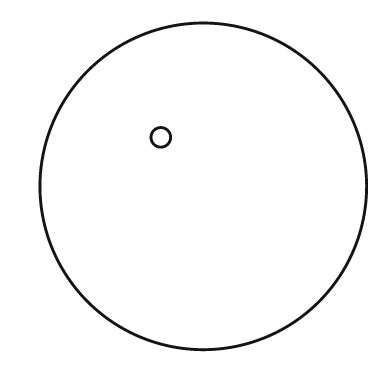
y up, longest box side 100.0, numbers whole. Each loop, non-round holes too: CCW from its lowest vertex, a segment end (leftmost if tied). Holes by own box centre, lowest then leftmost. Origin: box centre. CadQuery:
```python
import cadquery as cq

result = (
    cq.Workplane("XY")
    .moveTo(0.0, 0.0)
    .circle(50.0)
    .moveTo(-13.0, 15.0)
    .circle(3.0)
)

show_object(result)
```